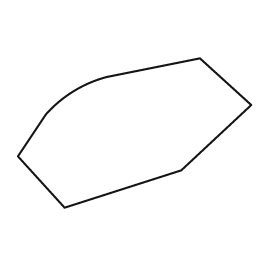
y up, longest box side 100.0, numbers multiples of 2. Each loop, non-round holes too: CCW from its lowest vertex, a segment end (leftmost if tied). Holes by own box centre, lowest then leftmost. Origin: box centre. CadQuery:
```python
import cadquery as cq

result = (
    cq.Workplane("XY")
    .moveTo(-30.0, -32.0)
    .lineTo(20.0, -16.0)
    .lineTo(50.0, 12.0)
    .lineTo(28.0, 32.0)
    .lineTo(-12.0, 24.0)
    .threePointArc((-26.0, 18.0), (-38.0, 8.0))
    .lineTo(-50.0, -10.0)
    .close()
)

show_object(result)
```